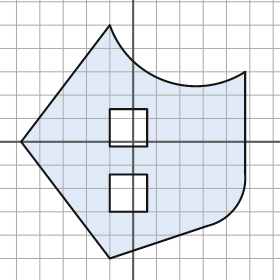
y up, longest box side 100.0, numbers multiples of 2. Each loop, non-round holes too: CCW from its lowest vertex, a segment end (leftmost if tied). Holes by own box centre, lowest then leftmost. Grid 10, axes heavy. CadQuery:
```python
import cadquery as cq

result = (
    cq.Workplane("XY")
    .moveTo(-10.0, -50.0)
    .lineTo(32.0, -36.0)
    .threePointArc((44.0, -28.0), (48.0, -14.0))
    .lineTo(48.0, 30.0)
    .threePointArc((14.0, 26.0), (-10.0, 50.0))
    .lineTo(-48.0, 0.0)
    .close()
    .moveTo(-10.0, -30.0)
    .lineTo(6.0, -30.0)
    .lineTo(6.0, -14.0)
    .lineTo(-10.0, -14.0)
    .close()
    .moveTo(-10.0, -2.0)
    .lineTo(6.0, -2.0)
    .lineTo(6.0, 14.0)
    .lineTo(-10.0, 14.0)
    .close()
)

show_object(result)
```